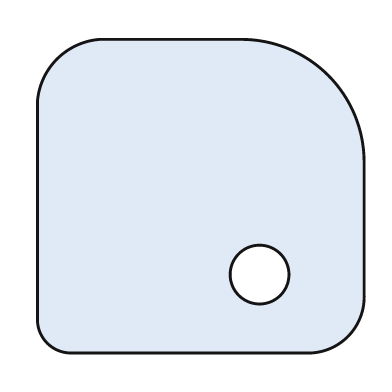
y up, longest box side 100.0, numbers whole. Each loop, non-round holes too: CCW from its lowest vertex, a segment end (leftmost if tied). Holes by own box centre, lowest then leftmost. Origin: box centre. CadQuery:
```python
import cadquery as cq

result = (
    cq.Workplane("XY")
    .moveTo(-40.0, -48.0)
    .lineTo(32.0, -48.0)
    .threePointArc((45.0, -43.0), (50.0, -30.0))
    .lineTo(50.0, 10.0)
    .threePointArc((39.0, 37.0), (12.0, 48.0))
    .lineTo(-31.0, 48.0)
    .threePointArc((-44.0, 42.0), (-50.0, 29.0))
    .lineTo(-50.0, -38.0)
    .threePointArc((-47.0, -45.0), (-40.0, -48.0))
    .close()
    .moveTo(18.0, -24.0)
    .circle(9.0)
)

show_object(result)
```